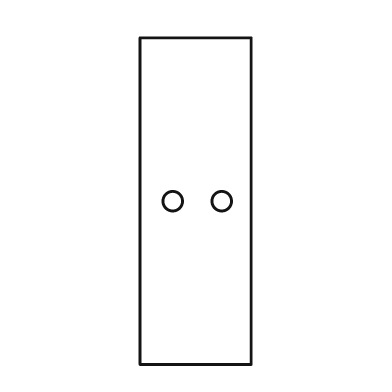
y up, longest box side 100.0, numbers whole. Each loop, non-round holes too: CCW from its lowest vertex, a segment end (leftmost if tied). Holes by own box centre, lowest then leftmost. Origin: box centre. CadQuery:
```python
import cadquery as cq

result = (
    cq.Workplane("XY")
    .moveTo(-17.0, -50.0)
    .lineTo(17.0, -50.0)
    .lineTo(17.0, 50.0)
    .lineTo(-17.0, 50.0)
    .close()
    .moveTo(-7.0, 0.0)
    .circle(3.0)
    .moveTo(8.0, 0.0)
    .circle(3.0)
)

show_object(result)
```